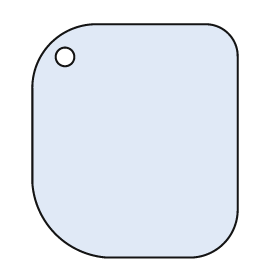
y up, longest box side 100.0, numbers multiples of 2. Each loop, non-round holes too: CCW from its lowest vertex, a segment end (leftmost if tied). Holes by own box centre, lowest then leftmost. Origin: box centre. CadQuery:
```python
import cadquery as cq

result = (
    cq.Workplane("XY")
    .moveTo(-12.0, -50.0)
    .lineTo(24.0, -50.0)
    .threePointArc((38.0, -44.0), (44.0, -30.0))
    .lineTo(44.0, 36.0)
    .threePointArc((40.0, 46.0), (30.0, 50.0))
    .lineTo(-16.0, 50.0)
    .threePointArc((-36.0, 42.0), (-44.0, 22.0))
    .lineTo(-44.0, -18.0)
    .threePointArc((-34.0, -40.0), (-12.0, -50.0))
    .close()
    .moveTo(-30.0, 36.0)
    .circle(4.0)
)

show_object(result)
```